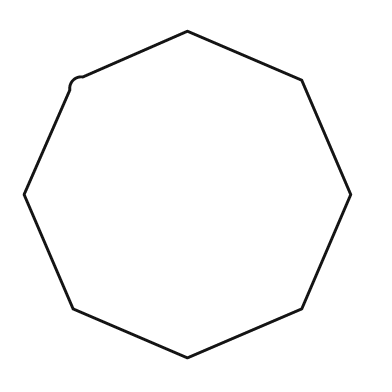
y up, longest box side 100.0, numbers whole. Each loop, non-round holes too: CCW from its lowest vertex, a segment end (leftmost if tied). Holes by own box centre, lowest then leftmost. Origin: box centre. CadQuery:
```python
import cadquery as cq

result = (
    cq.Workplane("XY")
    .moveTo(0.0, -50.0)
    .lineTo(35.0, -35.0)
    .lineTo(50.0, 0.0)
    .lineTo(35.0, 35.0)
    .lineTo(0.0, 50.0)
    .lineTo(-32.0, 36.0)
    .threePointArc((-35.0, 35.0), (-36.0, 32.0))
    .lineTo(-50.0, 0.0)
    .lineTo(-35.0, -35.0)
    .close()
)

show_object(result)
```